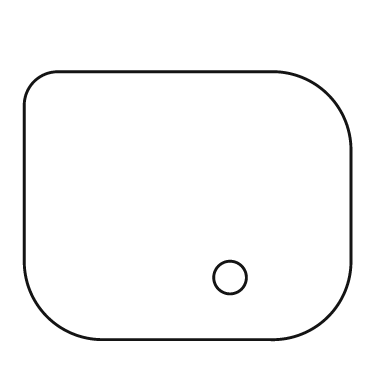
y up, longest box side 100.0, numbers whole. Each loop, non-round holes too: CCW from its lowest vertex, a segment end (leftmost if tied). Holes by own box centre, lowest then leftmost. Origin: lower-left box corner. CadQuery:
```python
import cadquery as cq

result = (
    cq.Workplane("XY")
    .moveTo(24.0, 0.0)
    .lineTo(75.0, 0.0)
    .threePointArc((93.0, 7.0), (100.0, 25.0))
    .lineTo(100.0, 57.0)
    .threePointArc((93.0, 75.0), (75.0, 82.0))
    .lineTo(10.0, 82.0)
    .threePointArc((3.0, 79.0), (0.0, 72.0))
    .lineTo(0.0, 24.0)
    .threePointArc((7.0, 7.0), (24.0, 0.0))
    .close()
    .moveTo(63.0, 19.0)
    .circle(5.0)
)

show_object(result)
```